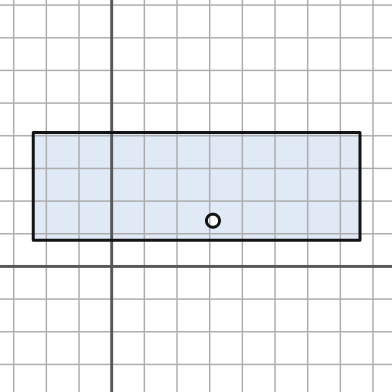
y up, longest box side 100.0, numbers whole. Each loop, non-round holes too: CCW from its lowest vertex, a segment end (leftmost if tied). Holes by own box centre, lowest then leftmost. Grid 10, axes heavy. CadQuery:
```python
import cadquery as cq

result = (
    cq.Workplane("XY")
    .moveTo(-24.0, 8.0)
    .lineTo(76.0, 8.0)
    .lineTo(76.0, 41.0)
    .lineTo(-24.0, 41.0)
    .close()
    .moveTo(31.0, 14.0)
    .circle(2.0)
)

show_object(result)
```